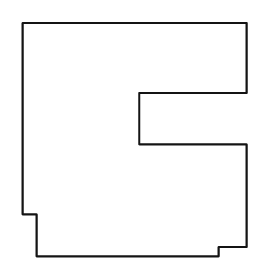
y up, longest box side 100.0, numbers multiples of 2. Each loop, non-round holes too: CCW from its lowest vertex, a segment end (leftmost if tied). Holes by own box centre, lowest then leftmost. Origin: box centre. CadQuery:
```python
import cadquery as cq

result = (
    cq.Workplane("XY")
    .moveTo(-42.0, -50.0)
    .lineTo(36.0, -50.0)
    .lineTo(36.0, -46.0)
    .lineTo(48.0, -46.0)
    .lineTo(48.0, -2.0)
    .lineTo(2.0, -2.0)
    .lineTo(2.0, 20.0)
    .lineTo(48.0, 20.0)
    .lineTo(48.0, 50.0)
    .lineTo(-48.0, 50.0)
    .lineTo(-48.0, -32.0)
    .lineTo(-42.0, -32.0)
    .close()
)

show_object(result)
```